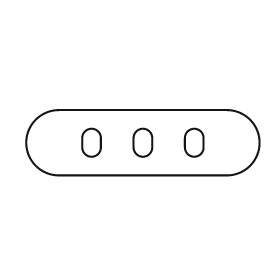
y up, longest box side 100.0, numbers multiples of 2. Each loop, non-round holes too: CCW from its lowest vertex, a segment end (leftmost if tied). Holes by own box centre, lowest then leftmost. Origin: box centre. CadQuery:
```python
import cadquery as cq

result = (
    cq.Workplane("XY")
    .moveTo(-36.0, -14.0)
    .lineTo(36.0, -14.0)
    .threePointArc((50.0, 0.0), (36.0, 14.0))
    .lineTo(-36.0, 14.0)
    .threePointArc((-50.0, 0.0), (-36.0, -14.0))
    .close()
    .moveTo(-26.0, -2.0)
    .threePointArc((-22.0, -6.0), (-18.0, -2.0))
    .lineTo(-18.0, 2.0)
    .threePointArc((-22.0, 6.0), (-26.0, 2.0))
    .close()
    .moveTo(-4.0, -2.0)
    .threePointArc((0.0, -6.0), (4.0, -2.0))
    .lineTo(4.0, 2.0)
    .threePointArc((0.0, 6.0), (-4.0, 2.0))
    .close()
    .moveTo(18.0, -2.0)
    .threePointArc((22.0, -6.0), (26.0, -2.0))
    .lineTo(26.0, 2.0)
    .threePointArc((22.0, 6.0), (18.0, 2.0))
    .close()
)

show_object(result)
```